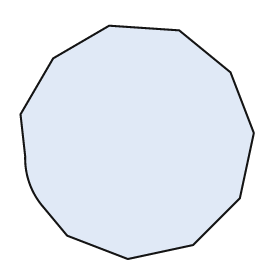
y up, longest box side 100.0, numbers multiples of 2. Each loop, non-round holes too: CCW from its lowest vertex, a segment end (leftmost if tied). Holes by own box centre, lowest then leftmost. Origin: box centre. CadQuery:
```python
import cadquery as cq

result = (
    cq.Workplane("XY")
    .moveTo(-4.0, -50.0)
    .lineTo(24.0, -44.0)
    .lineTo(44.0, -24.0)
    .lineTo(50.0, 4.0)
    .lineTo(40.0, 30.0)
    .lineTo(18.0, 48.0)
    .lineTo(-12.0, 50.0)
    .lineTo(-36.0, 36.0)
    .lineTo(-50.0, 12.0)
    .lineTo(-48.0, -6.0)
    .threePointArc((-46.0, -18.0), (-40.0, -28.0))
    .lineTo(-30.0, -40.0)
    .close()
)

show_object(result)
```